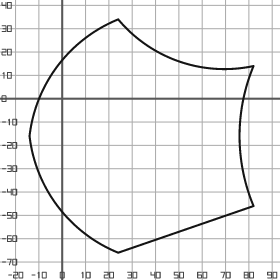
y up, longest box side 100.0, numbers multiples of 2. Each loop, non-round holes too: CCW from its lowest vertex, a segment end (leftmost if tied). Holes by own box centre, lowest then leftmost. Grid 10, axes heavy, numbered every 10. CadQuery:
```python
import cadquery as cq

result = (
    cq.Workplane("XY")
    .moveTo(24.0, -66.0)
    .lineTo(82.0, -46.0)
    .threePointArc((76.0, -16.0), (82.0, 14.0))
    .threePointArc((50.0, 16.0), (24.0, 34.0))
    .threePointArc((-2.0, 14.0), (-14.0, -16.0))
    .threePointArc((-2.0, -46.0), (24.0, -66.0))
    .close()
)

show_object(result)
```